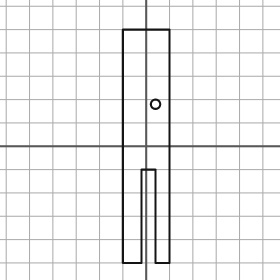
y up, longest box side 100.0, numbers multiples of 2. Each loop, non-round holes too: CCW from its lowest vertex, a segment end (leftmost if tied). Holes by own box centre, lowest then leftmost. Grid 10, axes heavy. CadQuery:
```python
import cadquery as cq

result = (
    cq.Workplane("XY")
    .moveTo(-10.0, -50.0)
    .lineTo(-2.0, -50.0)
    .lineTo(-2.0, -10.0)
    .lineTo(4.0, -10.0)
    .lineTo(4.0, -50.0)
    .lineTo(10.0, -50.0)
    .lineTo(10.0, 50.0)
    .lineTo(-10.0, 50.0)
    .close()
    .moveTo(4.0, 18.0)
    .circle(2.0)
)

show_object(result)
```